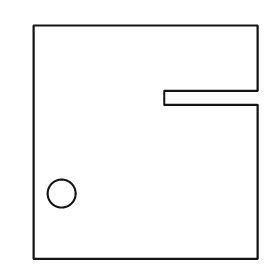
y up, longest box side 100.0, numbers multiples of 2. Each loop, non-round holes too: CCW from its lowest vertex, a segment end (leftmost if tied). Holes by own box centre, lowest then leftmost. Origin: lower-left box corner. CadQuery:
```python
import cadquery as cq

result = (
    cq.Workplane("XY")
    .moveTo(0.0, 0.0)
    .lineTo(96.0, 0.0)
    .lineTo(96.0, 66.0)
    .lineTo(56.0, 66.0)
    .lineTo(56.0, 72.0)
    .lineTo(96.0, 72.0)
    .lineTo(96.0, 100.0)
    .lineTo(0.0, 100.0)
    .close()
    .moveTo(12.0, 28.0)
    .circle(6.0)
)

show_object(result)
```